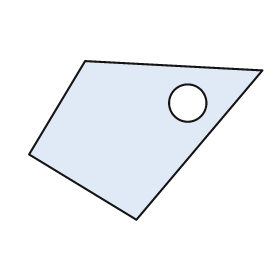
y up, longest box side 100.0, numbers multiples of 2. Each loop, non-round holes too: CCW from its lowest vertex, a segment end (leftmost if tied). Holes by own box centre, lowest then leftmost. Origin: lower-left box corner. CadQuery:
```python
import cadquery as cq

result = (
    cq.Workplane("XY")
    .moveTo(46.0, 0.0)
    .lineTo(100.0, 64.0)
    .lineTo(24.0, 68.0)
    .lineTo(0.0, 28.0)
    .close()
    .moveTo(68.0, 50.0)
    .circle(8.0)
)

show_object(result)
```